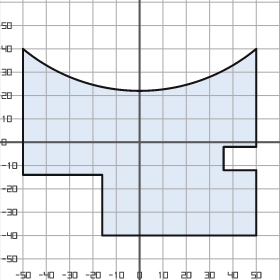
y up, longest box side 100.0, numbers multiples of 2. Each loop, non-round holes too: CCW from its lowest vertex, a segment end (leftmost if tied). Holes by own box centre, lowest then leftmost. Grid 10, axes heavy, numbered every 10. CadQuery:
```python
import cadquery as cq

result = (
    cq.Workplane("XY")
    .moveTo(-16.0, -40.0)
    .lineTo(50.0, -40.0)
    .lineTo(50.0, -12.0)
    .lineTo(36.0, -12.0)
    .lineTo(36.0, -2.0)
    .lineTo(50.0, -2.0)
    .lineTo(50.0, 40.0)
    .threePointArc((0.0, 22.0), (-50.0, 40.0))
    .lineTo(-50.0, -14.0)
    .lineTo(-16.0, -14.0)
    .close()
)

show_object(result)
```